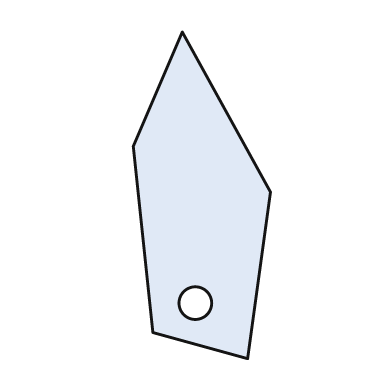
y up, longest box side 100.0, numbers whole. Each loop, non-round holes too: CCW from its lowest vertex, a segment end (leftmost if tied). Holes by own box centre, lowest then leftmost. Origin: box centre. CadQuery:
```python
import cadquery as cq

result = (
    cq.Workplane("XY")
    .moveTo(14.0, -50.0)
    .lineTo(21.0, 1.0)
    .lineTo(-6.0, 50.0)
    .lineTo(-21.0, 15.0)
    .lineTo(-15.0, -42.0)
    .close()
    .moveTo(-2.0, -33.0)
    .circle(5.0)
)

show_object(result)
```